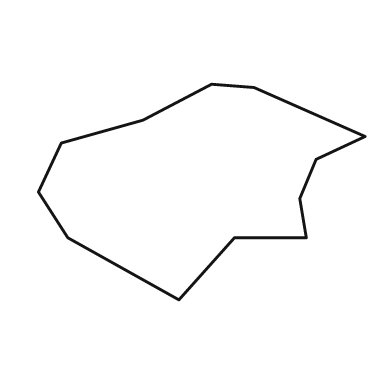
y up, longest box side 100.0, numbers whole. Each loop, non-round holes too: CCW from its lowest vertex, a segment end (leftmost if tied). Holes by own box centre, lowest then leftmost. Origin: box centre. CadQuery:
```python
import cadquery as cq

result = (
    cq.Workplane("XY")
    .moveTo(-7.0, -33.0)
    .lineTo(10.0, -14.0)
    .lineTo(32.0, -14.0)
    .lineTo(30.0, -2.0)
    .lineTo(35.0, 10.0)
    .lineTo(50.0, 17.0)
    .lineTo(16.0, 32.0)
    .lineTo(3.0, 33.0)
    .lineTo(-18.0, 22.0)
    .lineTo(-43.0, 15.0)
    .lineTo(-50.0, 0.0)
    .lineTo(-41.0, -14.0)
    .close()
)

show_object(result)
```